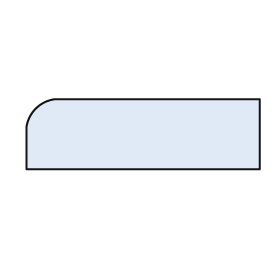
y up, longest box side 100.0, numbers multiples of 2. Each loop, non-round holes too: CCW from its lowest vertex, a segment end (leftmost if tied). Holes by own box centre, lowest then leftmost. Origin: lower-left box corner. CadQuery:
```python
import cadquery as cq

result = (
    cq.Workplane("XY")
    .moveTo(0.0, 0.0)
    .lineTo(100.0, 0.0)
    .lineTo(100.0, 30.0)
    .lineTo(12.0, 30.0)
    .threePointArc((4.0, 26.0), (0.0, 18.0))
    .close()
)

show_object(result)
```